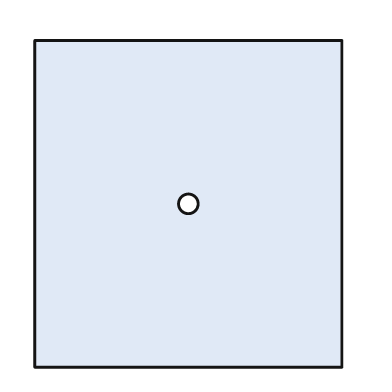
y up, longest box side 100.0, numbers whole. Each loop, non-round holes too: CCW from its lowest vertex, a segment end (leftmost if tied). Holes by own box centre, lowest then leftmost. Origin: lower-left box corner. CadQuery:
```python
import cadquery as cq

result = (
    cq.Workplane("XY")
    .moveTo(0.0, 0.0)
    .lineTo(94.0, 0.0)
    .lineTo(94.0, 100.0)
    .lineTo(0.0, 100.0)
    .close()
    .moveTo(47.0, 50.0)
    .circle(3.0)
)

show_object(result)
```